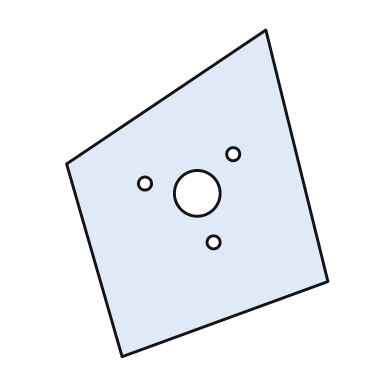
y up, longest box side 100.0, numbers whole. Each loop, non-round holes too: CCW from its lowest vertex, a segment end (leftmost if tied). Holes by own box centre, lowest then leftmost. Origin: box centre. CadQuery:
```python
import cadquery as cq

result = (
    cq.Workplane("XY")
    .moveTo(-23.0, -50.0)
    .lineTo(40.0, -27.0)
    .lineTo(21.0, 50.0)
    .lineTo(-40.0, 9.0)
    .close()
    .moveTo(5.0, -15.0)
    .circle(2.0)
    .moveTo(0.0, 0.0)
    .circle(7.0)
    .moveTo(-16.0, 3.0)
    .circle(2.0)
    .moveTo(11.0, 12.0)
    .circle(2.0)
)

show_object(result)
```